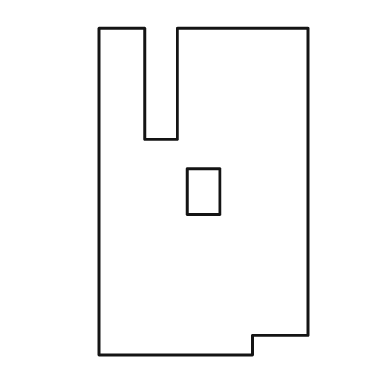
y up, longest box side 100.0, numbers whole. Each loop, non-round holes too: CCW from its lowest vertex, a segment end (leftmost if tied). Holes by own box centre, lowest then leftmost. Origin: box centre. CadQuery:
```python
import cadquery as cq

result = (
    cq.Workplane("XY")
    .moveTo(-32.0, -50.0)
    .lineTo(15.0, -50.0)
    .lineTo(15.0, -44.0)
    .lineTo(32.0, -44.0)
    .lineTo(32.0, 50.0)
    .lineTo(-8.0, 50.0)
    .lineTo(-8.0, 16.0)
    .lineTo(-18.0, 16.0)
    .lineTo(-18.0, 50.0)
    .lineTo(-32.0, 50.0)
    .close()
    .moveTo(-5.0, -7.0)
    .lineTo(5.0, -7.0)
    .lineTo(5.0, 7.0)
    .lineTo(-5.0, 7.0)
    .close()
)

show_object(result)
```